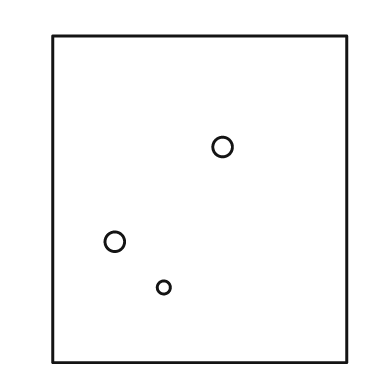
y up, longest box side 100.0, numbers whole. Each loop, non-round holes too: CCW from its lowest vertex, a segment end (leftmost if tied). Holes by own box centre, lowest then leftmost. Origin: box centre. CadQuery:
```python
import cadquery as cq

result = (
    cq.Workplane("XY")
    .moveTo(-45.0, -50.0)
    .lineTo(45.0, -50.0)
    .lineTo(45.0, 50.0)
    .lineTo(-45.0, 50.0)
    .close()
    .moveTo(-11.0, -27.0)
    .circle(2.0)
    .moveTo(-26.0, -13.0)
    .circle(3.0)
    .moveTo(7.0, 16.0)
    .circle(3.0)
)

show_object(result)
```